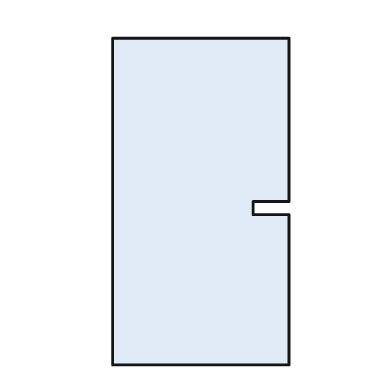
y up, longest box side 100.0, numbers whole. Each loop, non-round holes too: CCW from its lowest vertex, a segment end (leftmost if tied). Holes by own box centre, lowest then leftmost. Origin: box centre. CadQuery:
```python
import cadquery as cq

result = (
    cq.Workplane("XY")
    .moveTo(-27.0, -50.0)
    .lineTo(27.0, -50.0)
    .lineTo(27.0, -4.0)
    .lineTo(16.0, -4.0)
    .lineTo(16.0, 0.0)
    .lineTo(27.0, 0.0)
    .lineTo(27.0, 50.0)
    .lineTo(-27.0, 50.0)
    .close()
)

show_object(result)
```